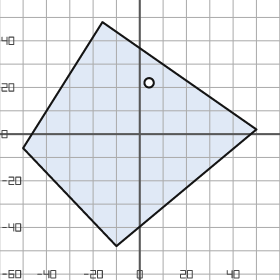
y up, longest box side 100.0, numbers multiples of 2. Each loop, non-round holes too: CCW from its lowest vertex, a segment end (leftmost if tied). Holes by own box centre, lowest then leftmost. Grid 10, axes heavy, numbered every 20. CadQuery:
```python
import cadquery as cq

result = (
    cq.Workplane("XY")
    .moveTo(-10.0, -48.0)
    .lineTo(50.0, 2.0)
    .lineTo(-16.0, 48.0)
    .lineTo(-50.0, -6.0)
    .close()
    .moveTo(4.0, 22.0)
    .circle(2.0)
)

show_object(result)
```